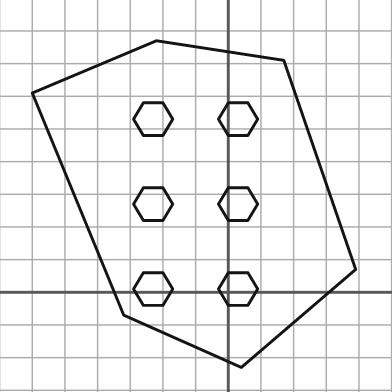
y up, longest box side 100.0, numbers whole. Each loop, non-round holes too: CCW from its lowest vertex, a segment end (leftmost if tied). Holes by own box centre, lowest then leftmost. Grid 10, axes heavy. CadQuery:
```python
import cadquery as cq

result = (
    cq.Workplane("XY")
    .moveTo(4.0, -23.0)
    .lineTo(39.0, 7.0)
    .lineTo(17.0, 71.0)
    .lineTo(-22.0, 77.0)
    .lineTo(-60.0, 61.0)
    .lineTo(-32.0, -7.0)
    .close()
    .moveTo(-26.0, -4.0)
    .lineTo(-20.0, -4.0)
    .lineTo(-17.0, 1.0)
    .lineTo(-20.0, 6.0)
    .lineTo(-26.0, 6.0)
    .lineTo(-29.0, 1.0)
    .close()
    .moveTo(0.0, -4.0)
    .lineTo(6.0, -4.0)
    .lineTo(9.0, 1.0)
    .lineTo(6.0, 6.0)
    .lineTo(0.0, 6.0)
    .lineTo(-3.0, 1.0)
    .close()
    .moveTo(-26.0, 22.0)
    .lineTo(-20.0, 22.0)
    .lineTo(-17.0, 27.0)
    .lineTo(-20.0, 32.0)
    .lineTo(-26.0, 32.0)
    .lineTo(-29.0, 27.0)
    .close()
    .moveTo(0.0, 22.0)
    .lineTo(6.0, 22.0)
    .lineTo(9.0, 27.0)
    .lineTo(6.0, 32.0)
    .lineTo(0.0, 32.0)
    .lineTo(-3.0, 27.0)
    .close()
    .moveTo(-26.0, 48.0)
    .lineTo(-20.0, 48.0)
    .lineTo(-17.0, 53.0)
    .lineTo(-20.0, 58.0)
    .lineTo(-26.0, 58.0)
    .lineTo(-29.0, 53.0)
    .close()
    .moveTo(0.0, 48.0)
    .lineTo(6.0, 48.0)
    .lineTo(9.0, 53.0)
    .lineTo(6.0, 58.0)
    .lineTo(0.0, 58.0)
    .lineTo(-3.0, 53.0)
    .close()
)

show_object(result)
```